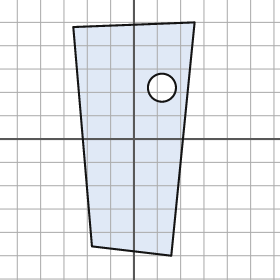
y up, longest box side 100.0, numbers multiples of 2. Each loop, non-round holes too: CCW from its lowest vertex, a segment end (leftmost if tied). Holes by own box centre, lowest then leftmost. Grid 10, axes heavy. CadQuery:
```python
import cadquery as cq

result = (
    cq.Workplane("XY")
    .moveTo(16.0, -50.0)
    .lineTo(26.0, 50.0)
    .lineTo(-26.0, 48.0)
    .lineTo(-18.0, -46.0)
    .close()
    .moveTo(12.0, 22.0)
    .circle(6.0)
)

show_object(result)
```